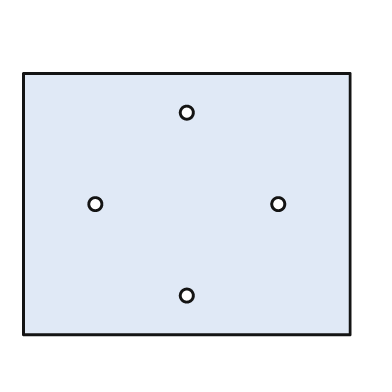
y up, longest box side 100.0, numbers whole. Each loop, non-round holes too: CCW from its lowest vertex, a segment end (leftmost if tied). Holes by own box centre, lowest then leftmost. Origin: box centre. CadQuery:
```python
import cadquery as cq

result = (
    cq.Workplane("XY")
    .moveTo(-50.0, -40.0)
    .lineTo(50.0, -40.0)
    .lineTo(50.0, 40.0)
    .lineTo(-50.0, 40.0)
    .close()
    .moveTo(0.0, -28.0)
    .circle(2.0)
    .moveTo(-28.0, 0.0)
    .circle(2.0)
    .moveTo(28.0, 0.0)
    .circle(2.0)
    .moveTo(0.0, 28.0)
    .circle(2.0)
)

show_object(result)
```